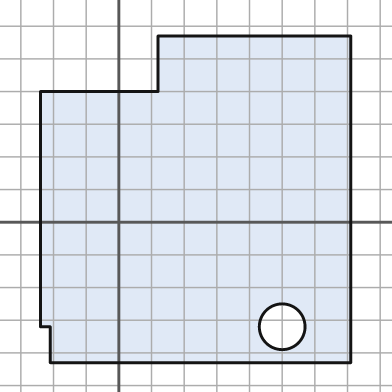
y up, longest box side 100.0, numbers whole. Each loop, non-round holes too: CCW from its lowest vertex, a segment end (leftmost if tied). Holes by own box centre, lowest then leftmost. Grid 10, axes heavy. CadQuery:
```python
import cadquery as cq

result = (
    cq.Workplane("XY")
    .moveTo(-21.0, -43.0)
    .lineTo(71.0, -43.0)
    .lineTo(71.0, 57.0)
    .lineTo(12.0, 57.0)
    .lineTo(12.0, 40.0)
    .lineTo(-24.0, 40.0)
    .lineTo(-24.0, -32.0)
    .lineTo(-21.0, -32.0)
    .close()
    .moveTo(50.0, -32.0)
    .circle(7.0)
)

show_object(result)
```